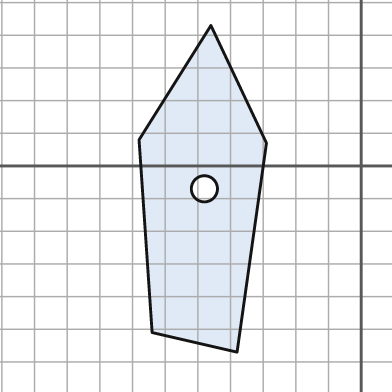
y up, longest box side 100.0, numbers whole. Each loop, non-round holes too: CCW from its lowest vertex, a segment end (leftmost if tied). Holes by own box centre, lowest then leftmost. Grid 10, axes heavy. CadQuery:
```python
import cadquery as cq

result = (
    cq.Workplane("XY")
    .moveTo(-38.0, -57.0)
    .lineTo(-29.0, 7.0)
    .lineTo(-46.0, 43.0)
    .lineTo(-68.0, 8.0)
    .lineTo(-64.0, -51.0)
    .close()
    .moveTo(-48.0, -7.0)
    .circle(4.0)
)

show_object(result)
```